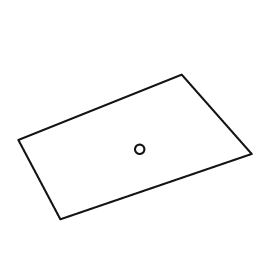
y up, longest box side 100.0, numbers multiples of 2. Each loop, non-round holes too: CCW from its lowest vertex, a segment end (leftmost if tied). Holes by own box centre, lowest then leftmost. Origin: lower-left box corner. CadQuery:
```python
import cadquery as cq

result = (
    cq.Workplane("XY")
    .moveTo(18.0, 0.0)
    .lineTo(100.0, 28.0)
    .lineTo(70.0, 62.0)
    .lineTo(0.0, 34.0)
    .close()
    .moveTo(52.0, 30.0)
    .circle(2.0)
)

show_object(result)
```